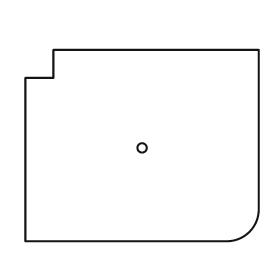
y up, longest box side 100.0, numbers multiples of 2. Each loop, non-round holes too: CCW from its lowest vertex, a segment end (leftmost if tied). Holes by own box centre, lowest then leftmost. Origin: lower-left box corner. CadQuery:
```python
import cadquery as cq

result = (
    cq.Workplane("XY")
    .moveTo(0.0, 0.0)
    .lineTo(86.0, 0.0)
    .threePointArc((96.0, 4.0), (100.0, 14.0))
    .lineTo(100.0, 82.0)
    .lineTo(12.0, 82.0)
    .lineTo(12.0, 70.0)
    .lineTo(0.0, 70.0)
    .close()
    .moveTo(50.0, 40.0)
    .circle(2.0)
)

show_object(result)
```